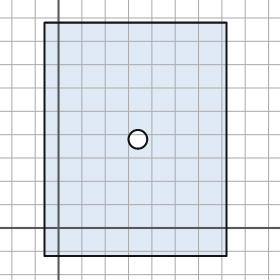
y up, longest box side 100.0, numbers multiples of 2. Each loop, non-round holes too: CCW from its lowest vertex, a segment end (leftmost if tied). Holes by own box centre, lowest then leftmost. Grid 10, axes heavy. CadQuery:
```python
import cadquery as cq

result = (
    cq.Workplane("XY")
    .moveTo(-6.0, -12.0)
    .lineTo(72.0, -12.0)
    .lineTo(72.0, 88.0)
    .lineTo(-6.0, 88.0)
    .close()
    .moveTo(34.0, 38.0)
    .circle(4.0)
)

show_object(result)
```